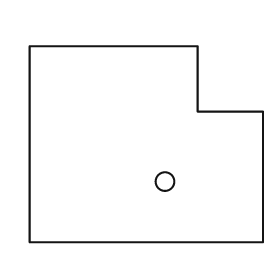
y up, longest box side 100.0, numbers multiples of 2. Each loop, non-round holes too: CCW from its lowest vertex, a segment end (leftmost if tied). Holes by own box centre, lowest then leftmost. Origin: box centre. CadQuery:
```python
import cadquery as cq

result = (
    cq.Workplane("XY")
    .moveTo(-50.0, -42.0)
    .lineTo(50.0, -42.0)
    .lineTo(50.0, 14.0)
    .lineTo(22.0, 14.0)
    .lineTo(22.0, 42.0)
    .lineTo(-50.0, 42.0)
    .close()
    .moveTo(8.0, -16.0)
    .circle(4.0)
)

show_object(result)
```